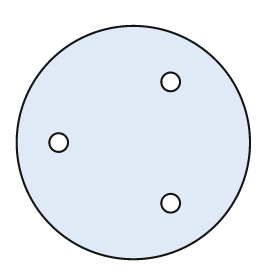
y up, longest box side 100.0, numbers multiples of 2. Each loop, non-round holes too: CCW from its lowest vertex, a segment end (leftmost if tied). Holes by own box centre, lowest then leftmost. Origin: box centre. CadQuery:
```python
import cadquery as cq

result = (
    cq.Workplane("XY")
    .moveTo(0.0, 0.0)
    .circle(50.0)
    .moveTo(16.0, -26.0)
    .circle(4.0)
    .moveTo(-32.0, 0.0)
    .circle(4.0)
    .moveTo(16.0, 26.0)
    .circle(4.0)
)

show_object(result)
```